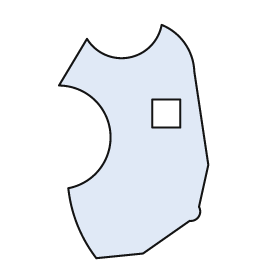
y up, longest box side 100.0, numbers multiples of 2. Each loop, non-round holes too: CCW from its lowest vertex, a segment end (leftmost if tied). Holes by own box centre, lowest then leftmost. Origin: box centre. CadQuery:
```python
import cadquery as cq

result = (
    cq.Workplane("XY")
    .moveTo(-16.0, -50.0)
    .lineTo(4.0, -48.0)
    .lineTo(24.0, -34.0)
    .threePointArc((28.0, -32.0), (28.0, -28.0))
    .lineTo(32.0, -10.0)
    .lineTo(26.0, 30.0)
    .threePointArc((22.0, 42.0), (12.0, 50.0))
    .threePointArc((-2.0, 36.0), (-20.0, 44.0))
    .lineTo(-32.0, 24.0)
    .threePointArc((-10.0, 4.0), (-28.0, -20.0))
    .threePointArc((-24.0, -36.0), (-16.0, -50.0))
    .close()
    .moveTo(8.0, 6.0)
    .lineTo(20.0, 6.0)
    .lineTo(20.0, 18.0)
    .lineTo(8.0, 18.0)
    .close()
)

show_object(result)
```